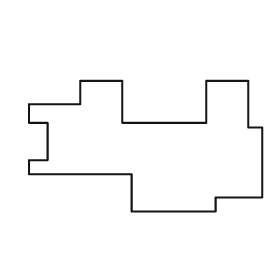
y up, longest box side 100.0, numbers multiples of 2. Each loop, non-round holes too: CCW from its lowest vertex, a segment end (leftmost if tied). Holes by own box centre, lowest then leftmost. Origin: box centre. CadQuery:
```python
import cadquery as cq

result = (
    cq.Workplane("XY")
    .moveTo(-6.0, -28.0)
    .lineTo(30.0, -28.0)
    .lineTo(30.0, -22.0)
    .lineTo(50.0, -22.0)
    .lineTo(50.0, 8.0)
    .lineTo(44.0, 8.0)
    .lineTo(44.0, 28.0)
    .lineTo(26.0, 28.0)
    .lineTo(26.0, 10.0)
    .lineTo(-10.0, 10.0)
    .lineTo(-10.0, 28.0)
    .lineTo(-28.0, 28.0)
    .lineTo(-28.0, 18.0)
    .lineTo(-50.0, 18.0)
    .lineTo(-50.0, 10.0)
    .lineTo(-42.0, 10.0)
    .lineTo(-42.0, -6.0)
    .lineTo(-50.0, -6.0)
    .lineTo(-50.0, -12.0)
    .lineTo(-6.0, -12.0)
    .close()
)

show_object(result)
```